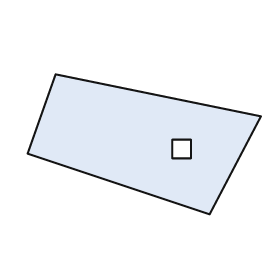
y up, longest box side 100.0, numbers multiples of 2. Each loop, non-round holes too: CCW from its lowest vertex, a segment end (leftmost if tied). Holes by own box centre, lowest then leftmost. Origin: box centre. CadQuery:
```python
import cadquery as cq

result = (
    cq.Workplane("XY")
    .moveTo(28.0, -30.0)
    .lineTo(50.0, 12.0)
    .lineTo(-38.0, 30.0)
    .lineTo(-50.0, -4.0)
    .close()
    .moveTo(12.0, -6.0)
    .lineTo(20.0, -6.0)
    .lineTo(20.0, 2.0)
    .lineTo(12.0, 2.0)
    .close()
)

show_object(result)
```